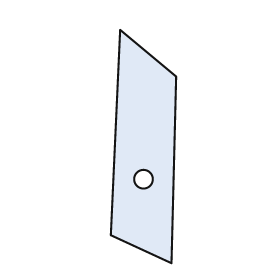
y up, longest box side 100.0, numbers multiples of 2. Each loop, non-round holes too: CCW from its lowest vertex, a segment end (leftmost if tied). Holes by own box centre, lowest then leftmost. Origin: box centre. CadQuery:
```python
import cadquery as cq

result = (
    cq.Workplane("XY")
    .moveTo(12.0, -50.0)
    .lineTo(14.0, 30.0)
    .lineTo(-10.0, 50.0)
    .lineTo(-14.0, -38.0)
    .close()
    .moveTo(0.0, -14.0)
    .circle(4.0)
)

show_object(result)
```